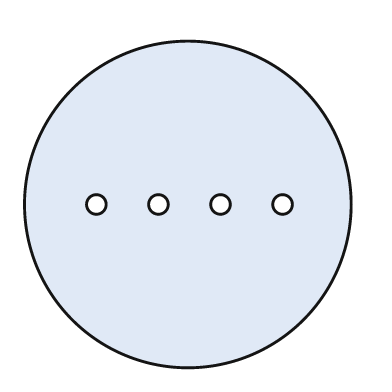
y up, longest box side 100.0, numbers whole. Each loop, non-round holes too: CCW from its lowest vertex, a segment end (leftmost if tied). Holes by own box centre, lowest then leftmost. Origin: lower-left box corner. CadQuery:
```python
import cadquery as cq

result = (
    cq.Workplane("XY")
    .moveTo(50.0, 50.0)
    .circle(50.0)
    .moveTo(22.0, 50.0)
    .circle(3.0)
    .moveTo(41.0, 50.0)
    .circle(3.0)
    .moveTo(60.0, 50.0)
    .circle(3.0)
    .moveTo(79.0, 50.0)
    .circle(3.0)
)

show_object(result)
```